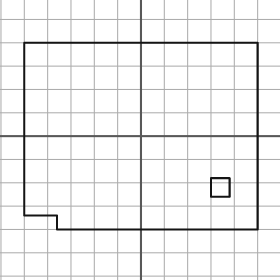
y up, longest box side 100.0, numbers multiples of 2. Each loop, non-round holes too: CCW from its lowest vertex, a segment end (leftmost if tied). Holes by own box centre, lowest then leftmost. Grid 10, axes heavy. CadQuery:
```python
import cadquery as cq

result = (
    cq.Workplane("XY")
    .moveTo(-36.0, -40.0)
    .lineTo(50.0, -40.0)
    .lineTo(50.0, 40.0)
    .lineTo(-50.0, 40.0)
    .lineTo(-50.0, -34.0)
    .lineTo(-36.0, -34.0)
    .close()
    .moveTo(30.0, -26.0)
    .lineTo(38.0, -26.0)
    .lineTo(38.0, -18.0)
    .lineTo(30.0, -18.0)
    .close()
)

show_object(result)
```